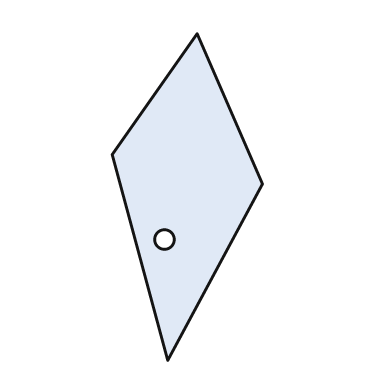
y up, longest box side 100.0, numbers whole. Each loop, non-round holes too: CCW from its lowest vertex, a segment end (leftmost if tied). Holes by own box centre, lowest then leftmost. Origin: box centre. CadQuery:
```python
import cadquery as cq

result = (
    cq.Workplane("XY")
    .moveTo(-6.0, -50.0)
    .lineTo(23.0, 4.0)
    .lineTo(3.0, 50.0)
    .lineTo(-23.0, 13.0)
    .close()
    .moveTo(-7.0, -13.0)
    .circle(3.0)
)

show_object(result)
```